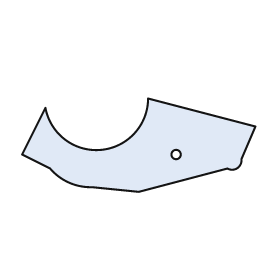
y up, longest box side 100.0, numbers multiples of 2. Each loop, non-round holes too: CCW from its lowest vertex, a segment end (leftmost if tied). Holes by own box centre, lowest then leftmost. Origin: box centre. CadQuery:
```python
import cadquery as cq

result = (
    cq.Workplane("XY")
    .moveTo(0.0, -20.0)
    .lineTo(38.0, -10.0)
    .threePointArc((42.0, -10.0), (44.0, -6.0))
    .lineTo(50.0, 8.0)
    .lineTo(4.0, 20.0)
    .threePointArc((-16.0, -2.0), (-40.0, 16.0))
    .lineTo(-50.0, -4.0)
    .lineTo(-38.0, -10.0)
    .threePointArc((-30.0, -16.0), (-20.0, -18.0))
    .close()
    .moveTo(16.0, -4.0)
    .circle(2.0)
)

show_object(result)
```